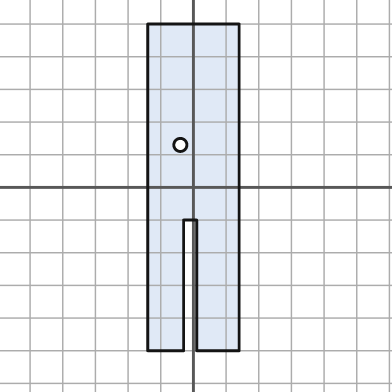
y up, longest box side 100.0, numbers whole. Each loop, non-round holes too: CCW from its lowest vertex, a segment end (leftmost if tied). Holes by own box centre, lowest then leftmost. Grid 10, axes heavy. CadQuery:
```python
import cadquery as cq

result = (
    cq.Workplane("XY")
    .moveTo(-14.0, -50.0)
    .lineTo(-3.0, -50.0)
    .lineTo(-3.0, -10.0)
    .lineTo(1.0, -10.0)
    .lineTo(1.0, -50.0)
    .lineTo(14.0, -50.0)
    .lineTo(14.0, 50.0)
    .lineTo(-14.0, 50.0)
    .close()
    .moveTo(-4.0, 13.0)
    .circle(2.0)
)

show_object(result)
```